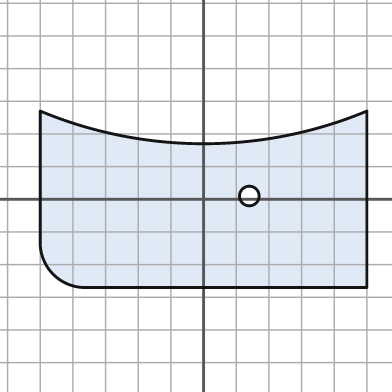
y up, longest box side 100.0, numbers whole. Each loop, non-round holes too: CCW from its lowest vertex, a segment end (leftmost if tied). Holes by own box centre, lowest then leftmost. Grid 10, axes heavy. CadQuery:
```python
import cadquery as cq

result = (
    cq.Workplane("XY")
    .moveTo(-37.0, -27.0)
    .lineTo(50.0, -27.0)
    .lineTo(50.0, 27.0)
    .threePointArc((0.0, 17.0), (-50.0, 27.0))
    .lineTo(-50.0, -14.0)
    .threePointArc((-46.0, -23.0), (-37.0, -27.0))
    .close()
    .moveTo(14.0, 1.0)
    .circle(3.0)
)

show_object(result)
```